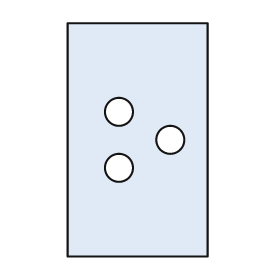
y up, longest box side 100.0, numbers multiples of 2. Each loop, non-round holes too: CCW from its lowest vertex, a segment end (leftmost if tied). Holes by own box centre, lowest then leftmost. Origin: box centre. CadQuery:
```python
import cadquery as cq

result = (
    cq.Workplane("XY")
    .moveTo(-30.0, -50.0)
    .lineTo(30.0, -50.0)
    .lineTo(30.0, 50.0)
    .lineTo(-30.0, 50.0)
    .close()
    .moveTo(-8.0, -12.0)
    .circle(6.0)
    .moveTo(14.0, 0.0)
    .circle(6.0)
    .moveTo(-8.0, 12.0)
    .circle(6.0)
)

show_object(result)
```